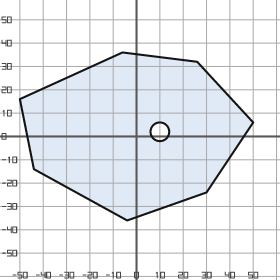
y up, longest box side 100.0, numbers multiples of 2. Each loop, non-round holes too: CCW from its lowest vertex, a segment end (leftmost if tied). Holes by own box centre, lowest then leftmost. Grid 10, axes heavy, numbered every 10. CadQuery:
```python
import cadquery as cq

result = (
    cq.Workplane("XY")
    .moveTo(-4.0, -36.0)
    .lineTo(30.0, -24.0)
    .lineTo(50.0, 6.0)
    .lineTo(26.0, 32.0)
    .lineTo(-6.0, 36.0)
    .lineTo(-50.0, 16.0)
    .lineTo(-44.0, -14.0)
    .close()
    .moveTo(10.0, 2.0)
    .circle(4.0)
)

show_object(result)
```